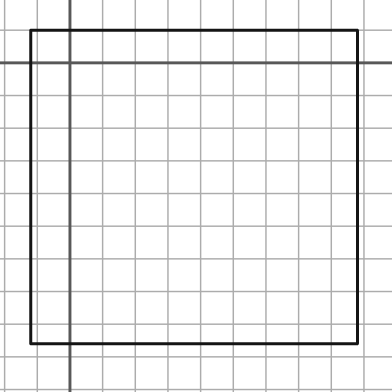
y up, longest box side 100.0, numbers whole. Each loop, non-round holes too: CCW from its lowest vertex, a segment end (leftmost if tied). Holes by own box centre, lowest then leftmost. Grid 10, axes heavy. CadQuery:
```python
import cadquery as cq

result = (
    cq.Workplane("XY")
    .moveTo(-12.0, -86.0)
    .lineTo(88.0, -86.0)
    .lineTo(88.0, 10.0)
    .lineTo(-12.0, 10.0)
    .close()
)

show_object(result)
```